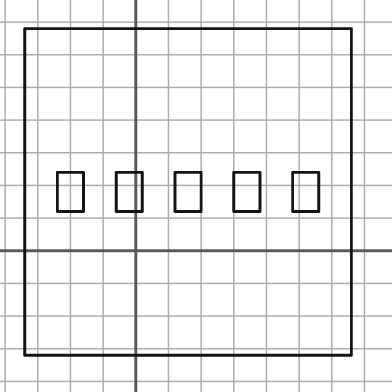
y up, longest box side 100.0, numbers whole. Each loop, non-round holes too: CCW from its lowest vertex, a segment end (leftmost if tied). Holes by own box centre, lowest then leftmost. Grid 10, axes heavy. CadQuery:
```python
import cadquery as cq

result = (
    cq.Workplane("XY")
    .moveTo(-34.0, -32.0)
    .lineTo(66.0, -32.0)
    .lineTo(66.0, 68.0)
    .lineTo(-34.0, 68.0)
    .close()
    .moveTo(-24.0, 12.0)
    .lineTo(-16.0, 12.0)
    .lineTo(-16.0, 24.0)
    .lineTo(-24.0, 24.0)
    .close()
    .moveTo(-6.0, 12.0)
    .lineTo(2.0, 12.0)
    .lineTo(2.0, 24.0)
    .lineTo(-6.0, 24.0)
    .close()
    .moveTo(12.0, 12.0)
    .lineTo(20.0, 12.0)
    .lineTo(20.0, 24.0)
    .lineTo(12.0, 24.0)
    .close()
    .moveTo(30.0, 12.0)
    .lineTo(38.0, 12.0)
    .lineTo(38.0, 24.0)
    .lineTo(30.0, 24.0)
    .close()
    .moveTo(48.0, 12.0)
    .lineTo(56.0, 12.0)
    .lineTo(56.0, 24.0)
    .lineTo(48.0, 24.0)
    .close()
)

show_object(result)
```